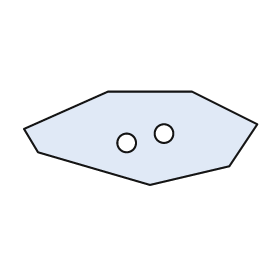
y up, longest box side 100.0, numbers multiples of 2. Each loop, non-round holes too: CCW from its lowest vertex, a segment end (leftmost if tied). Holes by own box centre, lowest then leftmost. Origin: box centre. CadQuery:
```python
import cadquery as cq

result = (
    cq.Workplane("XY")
    .moveTo(4.0, -20.0)
    .lineTo(38.0, -12.0)
    .lineTo(50.0, 6.0)
    .lineTo(22.0, 20.0)
    .lineTo(-14.0, 20.0)
    .lineTo(-50.0, 4.0)
    .lineTo(-44.0, -6.0)
    .close()
    .moveTo(-6.0, -2.0)
    .circle(4.0)
    .moveTo(10.0, 2.0)
    .circle(4.0)
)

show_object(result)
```